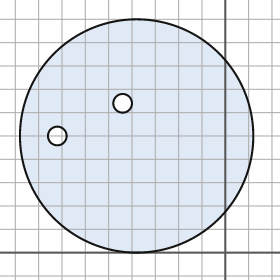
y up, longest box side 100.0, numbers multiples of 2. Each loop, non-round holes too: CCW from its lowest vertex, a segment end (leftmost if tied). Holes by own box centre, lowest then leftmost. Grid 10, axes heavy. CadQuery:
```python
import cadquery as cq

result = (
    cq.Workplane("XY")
    .moveTo(-38.0, 50.0)
    .circle(50.0)
    .moveTo(-72.0, 50.0)
    .circle(4.0)
    .moveTo(-44.0, 64.0)
    .circle(4.0)
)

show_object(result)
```